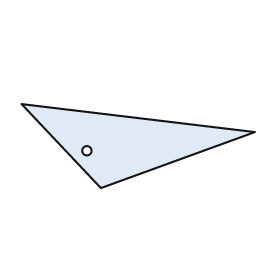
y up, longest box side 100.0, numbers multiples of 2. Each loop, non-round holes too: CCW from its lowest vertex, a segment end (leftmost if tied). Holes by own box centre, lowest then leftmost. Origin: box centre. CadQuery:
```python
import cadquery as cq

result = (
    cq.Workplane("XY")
    .moveTo(-16.0, -18.0)
    .lineTo(50.0, 6.0)
    .lineTo(-50.0, 18.0)
    .close()
    .moveTo(-22.0, -2.0)
    .circle(2.0)
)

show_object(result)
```